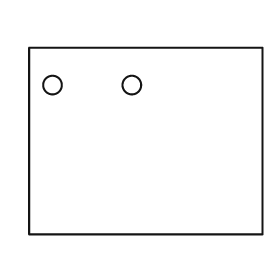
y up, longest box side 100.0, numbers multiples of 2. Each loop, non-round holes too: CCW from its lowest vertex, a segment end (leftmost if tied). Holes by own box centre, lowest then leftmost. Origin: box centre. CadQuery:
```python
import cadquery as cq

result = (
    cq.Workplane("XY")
    .moveTo(-50.0, -40.0)
    .lineTo(50.0, -40.0)
    .lineTo(50.0, 40.0)
    .lineTo(-50.0, 40.0)
    .close()
    .moveTo(-40.0, 24.0)
    .circle(4.0)
    .moveTo(-6.0, 24.0)
    .circle(4.0)
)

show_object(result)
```